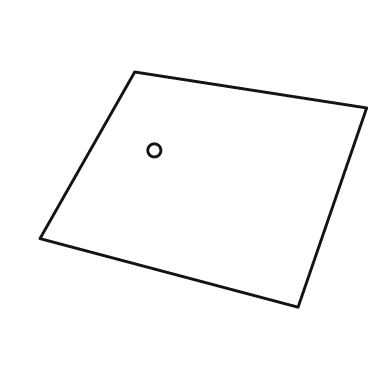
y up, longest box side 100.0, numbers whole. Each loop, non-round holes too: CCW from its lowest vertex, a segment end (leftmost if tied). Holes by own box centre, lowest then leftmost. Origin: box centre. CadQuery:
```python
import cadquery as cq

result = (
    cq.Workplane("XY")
    .moveTo(29.0, -36.0)
    .lineTo(50.0, 25.0)
    .lineTo(-21.0, 36.0)
    .lineTo(-50.0, -15.0)
    .close()
    .moveTo(-15.0, 12.0)
    .circle(2.0)
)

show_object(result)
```